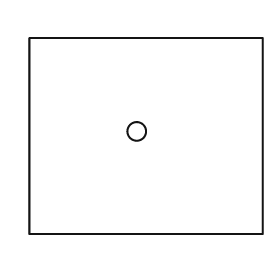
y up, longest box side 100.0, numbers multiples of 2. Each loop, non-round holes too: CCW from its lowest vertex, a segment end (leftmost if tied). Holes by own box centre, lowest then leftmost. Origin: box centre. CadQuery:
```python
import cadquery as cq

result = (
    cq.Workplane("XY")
    .moveTo(-50.0, -42.0)
    .lineTo(50.0, -42.0)
    .lineTo(50.0, 42.0)
    .lineTo(-50.0, 42.0)
    .close()
    .moveTo(-4.0, 2.0)
    .circle(4.0)
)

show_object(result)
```